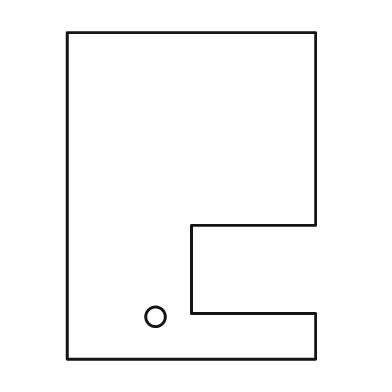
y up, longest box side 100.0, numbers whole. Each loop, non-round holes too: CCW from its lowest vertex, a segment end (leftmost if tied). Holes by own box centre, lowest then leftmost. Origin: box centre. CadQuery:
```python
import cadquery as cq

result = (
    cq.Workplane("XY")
    .moveTo(-38.0, -50.0)
    .lineTo(38.0, -50.0)
    .lineTo(38.0, -36.0)
    .lineTo(0.0, -36.0)
    .lineTo(0.0, -9.0)
    .lineTo(38.0, -9.0)
    .lineTo(38.0, 50.0)
    .lineTo(-38.0, 50.0)
    .close()
    .moveTo(-11.0, -37.0)
    .circle(3.0)
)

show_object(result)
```